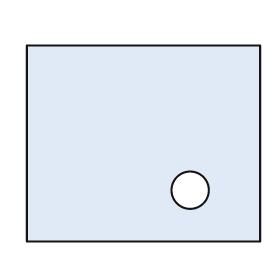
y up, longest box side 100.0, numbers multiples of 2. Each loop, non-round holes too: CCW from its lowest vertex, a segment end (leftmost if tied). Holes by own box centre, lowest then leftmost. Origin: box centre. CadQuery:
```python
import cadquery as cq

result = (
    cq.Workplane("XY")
    .moveTo(-50.0, -42.0)
    .lineTo(50.0, -42.0)
    .lineTo(50.0, 42.0)
    .lineTo(-50.0, 42.0)
    .close()
    .moveTo(20.0, -20.0)
    .circle(8.0)
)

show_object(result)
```